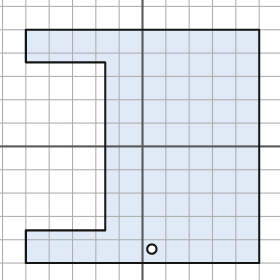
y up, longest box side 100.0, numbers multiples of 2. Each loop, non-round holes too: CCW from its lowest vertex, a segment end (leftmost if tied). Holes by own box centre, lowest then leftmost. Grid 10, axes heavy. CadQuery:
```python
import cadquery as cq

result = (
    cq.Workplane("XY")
    .moveTo(-50.0, -50.0)
    .lineTo(50.0, -50.0)
    .lineTo(50.0, 50.0)
    .lineTo(-50.0, 50.0)
    .lineTo(-50.0, 36.0)
    .lineTo(-16.0, 36.0)
    .lineTo(-16.0, -36.0)
    .lineTo(-50.0, -36.0)
    .close()
    .moveTo(4.0, -44.0)
    .circle(2.0)
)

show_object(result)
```